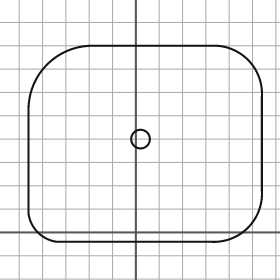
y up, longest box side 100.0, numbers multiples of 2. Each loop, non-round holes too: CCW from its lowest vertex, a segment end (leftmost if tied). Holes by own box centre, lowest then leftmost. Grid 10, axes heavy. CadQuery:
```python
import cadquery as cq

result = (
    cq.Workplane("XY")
    .moveTo(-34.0, -4.0)
    .lineTo(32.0, -4.0)
    .threePointArc((48.0, 2.0), (54.0, 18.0))
    .lineTo(54.0, 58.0)
    .threePointArc((48.0, 74.0), (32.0, 80.0))
    .lineTo(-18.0, 80.0)
    .threePointArc((-38.0, 72.0), (-46.0, 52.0))
    .lineTo(-46.0, 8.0)
    .threePointArc((-42.0, 0.0), (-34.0, -4.0))
    .close()
    .moveTo(2.0, 40.0)
    .circle(4.0)
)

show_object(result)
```